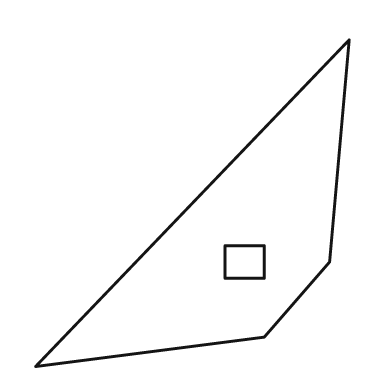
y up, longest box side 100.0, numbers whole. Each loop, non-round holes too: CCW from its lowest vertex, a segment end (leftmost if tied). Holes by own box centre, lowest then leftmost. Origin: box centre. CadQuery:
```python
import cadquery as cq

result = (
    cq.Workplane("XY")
    .moveTo(-48.0, -50.0)
    .lineTo(22.0, -41.0)
    .lineTo(42.0, -18.0)
    .lineTo(48.0, 50.0)
    .close()
    .moveTo(10.0, -23.0)
    .lineTo(22.0, -23.0)
    .lineTo(22.0, -13.0)
    .lineTo(10.0, -13.0)
    .close()
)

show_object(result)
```